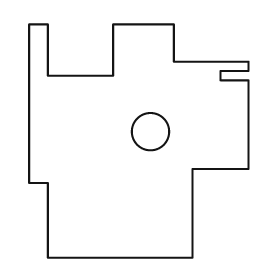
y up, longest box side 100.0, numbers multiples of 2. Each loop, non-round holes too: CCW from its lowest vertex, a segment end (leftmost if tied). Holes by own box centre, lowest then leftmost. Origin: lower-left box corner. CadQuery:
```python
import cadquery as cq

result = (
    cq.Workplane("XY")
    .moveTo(8.0, 0.0)
    .lineTo(70.0, 0.0)
    .lineTo(70.0, 38.0)
    .lineTo(94.0, 38.0)
    .lineTo(94.0, 76.0)
    .lineTo(82.0, 76.0)
    .lineTo(82.0, 80.0)
    .lineTo(94.0, 80.0)
    .lineTo(94.0, 84.0)
    .lineTo(62.0, 84.0)
    .lineTo(62.0, 100.0)
    .lineTo(36.0, 100.0)
    .lineTo(36.0, 78.0)
    .lineTo(8.0, 78.0)
    .lineTo(8.0, 100.0)
    .lineTo(0.0, 100.0)
    .lineTo(0.0, 32.0)
    .lineTo(8.0, 32.0)
    .close()
    .moveTo(52.0, 54.0)
    .circle(8.0)
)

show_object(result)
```